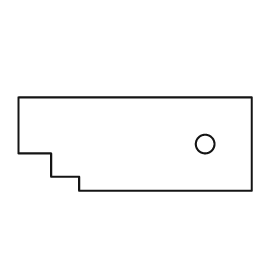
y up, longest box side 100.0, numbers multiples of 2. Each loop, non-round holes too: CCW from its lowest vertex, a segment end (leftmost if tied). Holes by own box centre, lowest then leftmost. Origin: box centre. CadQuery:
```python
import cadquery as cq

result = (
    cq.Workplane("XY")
    .moveTo(-24.0, -20.0)
    .lineTo(50.0, -20.0)
    .lineTo(50.0, 20.0)
    .lineTo(-50.0, 20.0)
    .lineTo(-50.0, -4.0)
    .lineTo(-36.0, -4.0)
    .lineTo(-36.0, -14.0)
    .lineTo(-24.0, -14.0)
    .close()
    .moveTo(30.0, 0.0)
    .circle(4.0)
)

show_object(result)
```